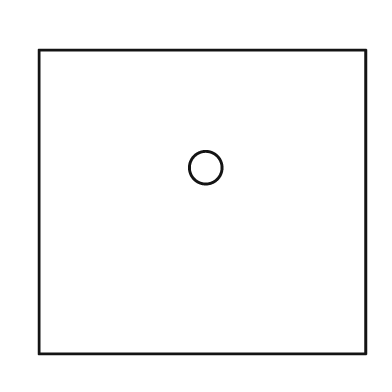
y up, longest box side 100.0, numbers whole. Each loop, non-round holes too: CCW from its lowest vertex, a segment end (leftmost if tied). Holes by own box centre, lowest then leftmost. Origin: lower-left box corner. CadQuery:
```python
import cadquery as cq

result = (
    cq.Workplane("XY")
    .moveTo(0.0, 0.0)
    .lineTo(100.0, 0.0)
    .lineTo(100.0, 93.0)
    .lineTo(0.0, 93.0)
    .close()
    .moveTo(51.0, 57.0)
    .circle(5.0)
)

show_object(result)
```